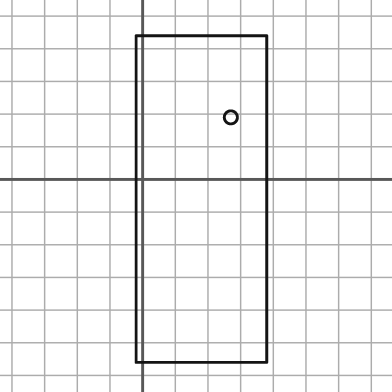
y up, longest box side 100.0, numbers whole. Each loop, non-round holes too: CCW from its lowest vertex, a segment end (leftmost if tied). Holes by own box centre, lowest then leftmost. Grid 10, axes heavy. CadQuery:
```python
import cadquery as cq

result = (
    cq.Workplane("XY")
    .moveTo(-2.0, -56.0)
    .lineTo(38.0, -56.0)
    .lineTo(38.0, 44.0)
    .lineTo(-2.0, 44.0)
    .close()
    .moveTo(27.0, 19.0)
    .circle(2.0)
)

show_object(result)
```